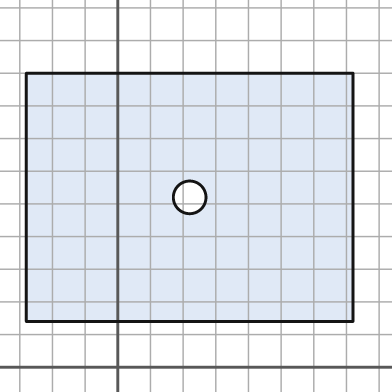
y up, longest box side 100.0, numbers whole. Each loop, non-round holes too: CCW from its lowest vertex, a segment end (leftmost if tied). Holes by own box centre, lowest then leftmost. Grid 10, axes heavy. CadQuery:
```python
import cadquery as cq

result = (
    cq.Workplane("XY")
    .moveTo(-28.0, 14.0)
    .lineTo(72.0, 14.0)
    .lineTo(72.0, 90.0)
    .lineTo(-28.0, 90.0)
    .close()
    .moveTo(22.0, 52.0)
    .circle(5.0)
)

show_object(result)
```